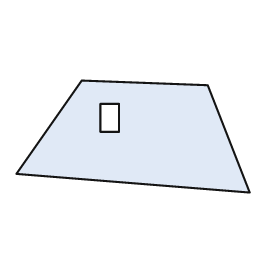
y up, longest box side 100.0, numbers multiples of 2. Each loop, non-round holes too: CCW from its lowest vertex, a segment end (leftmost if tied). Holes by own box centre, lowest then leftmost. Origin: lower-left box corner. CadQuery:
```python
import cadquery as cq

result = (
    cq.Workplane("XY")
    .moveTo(100.0, 0.0)
    .lineTo(82.0, 46.0)
    .lineTo(28.0, 48.0)
    .lineTo(0.0, 8.0)
    .close()
    .moveTo(36.0, 26.0)
    .lineTo(44.0, 26.0)
    .lineTo(44.0, 38.0)
    .lineTo(36.0, 38.0)
    .close()
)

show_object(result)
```